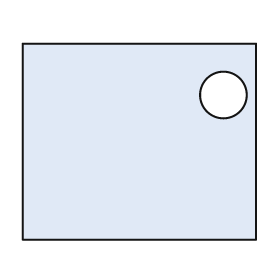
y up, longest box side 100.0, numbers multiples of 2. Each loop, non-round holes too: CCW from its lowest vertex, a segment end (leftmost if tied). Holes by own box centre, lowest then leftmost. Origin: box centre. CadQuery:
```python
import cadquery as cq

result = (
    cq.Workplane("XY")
    .moveTo(-50.0, -42.0)
    .lineTo(50.0, -42.0)
    .lineTo(50.0, 42.0)
    .lineTo(-50.0, 42.0)
    .close()
    .moveTo(36.0, 20.0)
    .circle(10.0)
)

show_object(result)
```